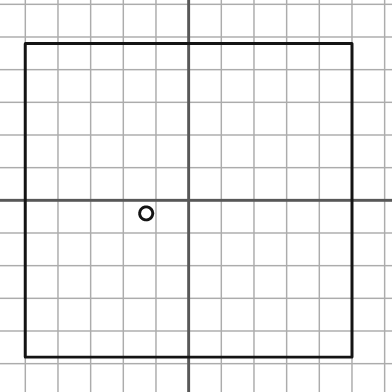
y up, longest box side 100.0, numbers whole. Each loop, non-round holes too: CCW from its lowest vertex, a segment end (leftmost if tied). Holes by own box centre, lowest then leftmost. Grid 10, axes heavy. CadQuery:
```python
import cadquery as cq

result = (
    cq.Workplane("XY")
    .moveTo(-50.0, -48.0)
    .lineTo(50.0, -48.0)
    .lineTo(50.0, 48.0)
    .lineTo(-50.0, 48.0)
    .close()
    .moveTo(-13.0, -4.0)
    .circle(2.0)
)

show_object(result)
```